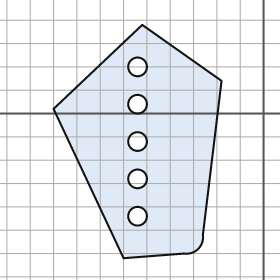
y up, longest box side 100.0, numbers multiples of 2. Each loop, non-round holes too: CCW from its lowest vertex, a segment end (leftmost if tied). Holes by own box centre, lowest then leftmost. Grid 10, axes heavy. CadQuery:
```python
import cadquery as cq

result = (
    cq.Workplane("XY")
    .moveTo(-60.0, -62.0)
    .lineTo(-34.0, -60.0)
    .threePointArc((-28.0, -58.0), (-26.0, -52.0))
    .lineTo(-18.0, 14.0)
    .lineTo(-52.0, 38.0)
    .lineTo(-90.0, 2.0)
    .close()
    .moveTo(-54.0, -44.0)
    .circle(4.0)
    .moveTo(-54.0, -28.0)
    .circle(4.0)
    .moveTo(-54.0, -12.0)
    .circle(4.0)
    .moveTo(-54.0, 4.0)
    .circle(4.0)
    .moveTo(-54.0, 20.0)
    .circle(4.0)
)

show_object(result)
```